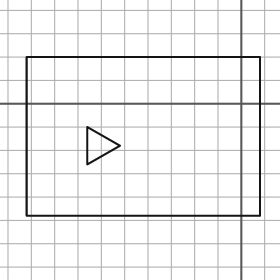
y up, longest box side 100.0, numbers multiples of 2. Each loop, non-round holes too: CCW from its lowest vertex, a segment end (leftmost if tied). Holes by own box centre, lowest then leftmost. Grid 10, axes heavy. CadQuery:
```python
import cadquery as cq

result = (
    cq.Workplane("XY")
    .moveTo(-92.0, -48.0)
    .lineTo(8.0, -48.0)
    .lineTo(8.0, 20.0)
    .lineTo(-92.0, 20.0)
    .close()
    .moveTo(-66.0, -26.0)
    .lineTo(-52.0, -18.0)
    .lineTo(-66.0, -10.0)
    .close()
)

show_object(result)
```